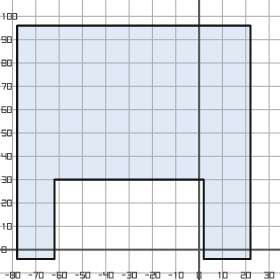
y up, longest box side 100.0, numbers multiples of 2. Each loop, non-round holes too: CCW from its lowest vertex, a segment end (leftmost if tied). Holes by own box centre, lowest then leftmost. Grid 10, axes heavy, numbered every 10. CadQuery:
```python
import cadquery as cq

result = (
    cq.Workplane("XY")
    .moveTo(-78.0, -4.0)
    .lineTo(-62.0, -4.0)
    .lineTo(-62.0, 30.0)
    .lineTo(2.0, 30.0)
    .lineTo(2.0, -4.0)
    .lineTo(22.0, -4.0)
    .lineTo(22.0, 96.0)
    .lineTo(-78.0, 96.0)
    .close()
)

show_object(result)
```